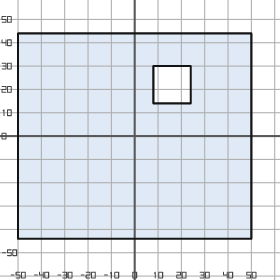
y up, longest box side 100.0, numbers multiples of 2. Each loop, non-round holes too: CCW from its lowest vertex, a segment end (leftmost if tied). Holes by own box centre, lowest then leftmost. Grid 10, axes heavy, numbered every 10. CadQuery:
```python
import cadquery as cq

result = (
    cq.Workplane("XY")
    .moveTo(-50.0, -44.0)
    .lineTo(50.0, -44.0)
    .lineTo(50.0, 44.0)
    .lineTo(-50.0, 44.0)
    .close()
    .moveTo(8.0, 14.0)
    .lineTo(24.0, 14.0)
    .lineTo(24.0, 30.0)
    .lineTo(8.0, 30.0)
    .close()
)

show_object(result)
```